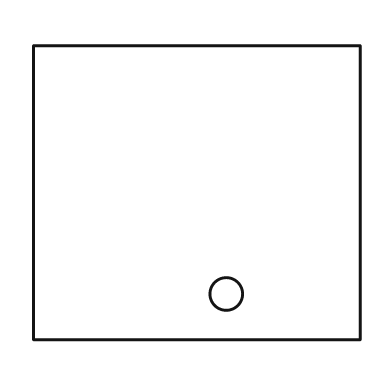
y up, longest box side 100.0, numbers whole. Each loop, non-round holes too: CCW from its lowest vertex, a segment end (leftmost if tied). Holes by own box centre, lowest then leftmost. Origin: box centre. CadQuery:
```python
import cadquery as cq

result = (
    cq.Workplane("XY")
    .moveTo(-50.0, -45.0)
    .lineTo(50.0, -45.0)
    .lineTo(50.0, 45.0)
    .lineTo(-50.0, 45.0)
    .close()
    .moveTo(9.0, -31.0)
    .circle(5.0)
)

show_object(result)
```